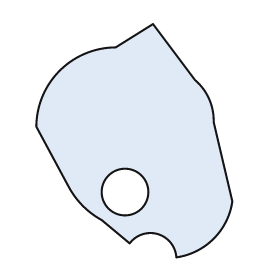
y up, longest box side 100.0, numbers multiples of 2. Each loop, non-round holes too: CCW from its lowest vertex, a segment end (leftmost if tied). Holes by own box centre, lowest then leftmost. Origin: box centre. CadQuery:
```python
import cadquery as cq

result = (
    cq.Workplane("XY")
    .moveTo(18.0, -50.0)
    .threePointArc((34.0, -42.0), (42.0, -26.0))
    .lineTo(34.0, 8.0)
    .threePointArc((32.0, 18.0), (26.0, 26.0))
    .lineTo(8.0, 50.0)
    .lineTo(-8.0, 40.0)
    .threePointArc((-32.0, 30.0), (-42.0, 6.0))
    .lineTo(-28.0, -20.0)
    .threePointArc((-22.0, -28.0), (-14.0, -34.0))
    .lineTo(-2.0, -44.0)
    .threePointArc((10.0, -40.0), (18.0, -50.0))
    .close()
    .moveTo(-4.0, -22.0)
    .circle(10.0)
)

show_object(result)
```